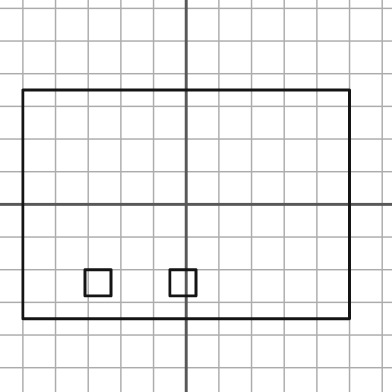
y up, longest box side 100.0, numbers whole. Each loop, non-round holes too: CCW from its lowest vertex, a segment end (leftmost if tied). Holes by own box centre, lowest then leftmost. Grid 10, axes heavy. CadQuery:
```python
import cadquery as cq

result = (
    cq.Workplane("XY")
    .moveTo(-50.0, -35.0)
    .lineTo(50.0, -35.0)
    .lineTo(50.0, 35.0)
    .lineTo(-50.0, 35.0)
    .close()
    .moveTo(-31.0, -28.0)
    .lineTo(-23.0, -28.0)
    .lineTo(-23.0, -20.0)
    .lineTo(-31.0, -20.0)
    .close()
    .moveTo(-5.0, -28.0)
    .lineTo(3.0, -28.0)
    .lineTo(3.0, -20.0)
    .lineTo(-5.0, -20.0)
    .close()
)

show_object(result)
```